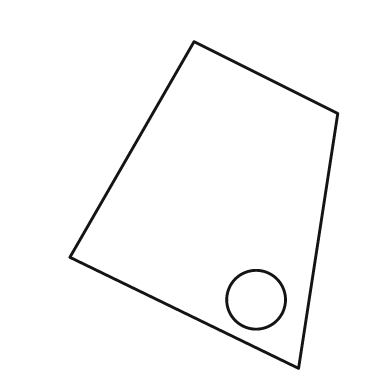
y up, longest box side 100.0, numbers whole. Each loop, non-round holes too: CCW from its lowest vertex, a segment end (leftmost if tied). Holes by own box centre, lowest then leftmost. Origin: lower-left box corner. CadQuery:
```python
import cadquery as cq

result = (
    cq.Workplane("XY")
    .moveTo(70.0, 0.0)
    .lineTo(82.0, 78.0)
    .lineTo(38.0, 100.0)
    .lineTo(0.0, 34.0)
    .close()
    .moveTo(57.0, 21.0)
    .circle(9.0)
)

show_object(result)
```